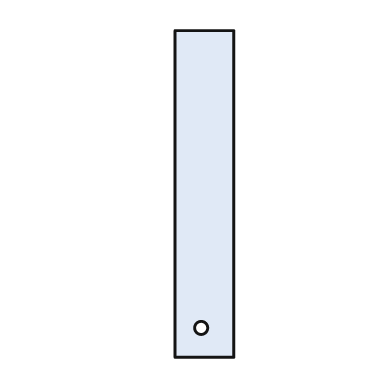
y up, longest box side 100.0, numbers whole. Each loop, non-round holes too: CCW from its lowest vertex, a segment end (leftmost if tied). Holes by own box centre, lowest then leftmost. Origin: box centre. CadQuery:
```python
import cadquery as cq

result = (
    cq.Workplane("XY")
    .moveTo(-9.0, -50.0)
    .lineTo(9.0, -50.0)
    .lineTo(9.0, 50.0)
    .lineTo(-9.0, 50.0)
    .close()
    .moveTo(-1.0, -41.0)
    .circle(2.0)
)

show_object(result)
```